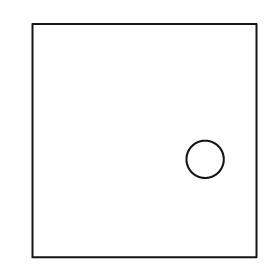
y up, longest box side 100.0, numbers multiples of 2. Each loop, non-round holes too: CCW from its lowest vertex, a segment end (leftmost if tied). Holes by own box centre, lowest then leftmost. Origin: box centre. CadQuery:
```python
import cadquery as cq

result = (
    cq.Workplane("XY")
    .moveTo(-48.0, -50.0)
    .lineTo(48.0, -50.0)
    .lineTo(48.0, 50.0)
    .lineTo(-48.0, 50.0)
    .close()
    .moveTo(26.0, -8.0)
    .circle(8.0)
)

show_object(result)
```